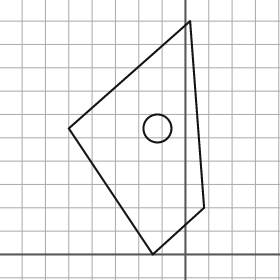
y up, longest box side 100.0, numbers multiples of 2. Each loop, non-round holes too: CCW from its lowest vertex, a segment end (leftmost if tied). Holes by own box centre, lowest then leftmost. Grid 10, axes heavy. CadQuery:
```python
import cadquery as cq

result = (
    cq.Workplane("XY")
    .moveTo(-14.0, 0.0)
    .lineTo(8.0, 20.0)
    .lineTo(2.0, 100.0)
    .lineTo(-50.0, 54.0)
    .close()
    .moveTo(-12.0, 54.0)
    .circle(6.0)
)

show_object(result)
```